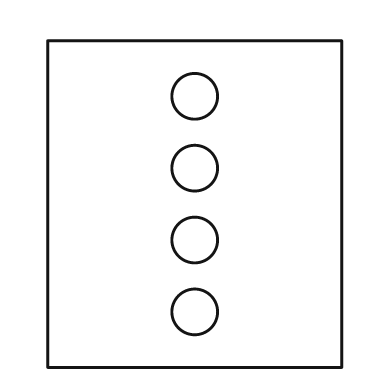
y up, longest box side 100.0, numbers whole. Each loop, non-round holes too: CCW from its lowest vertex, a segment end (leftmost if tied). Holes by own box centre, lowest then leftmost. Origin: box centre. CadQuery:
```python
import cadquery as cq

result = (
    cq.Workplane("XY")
    .moveTo(-45.0, -50.0)
    .lineTo(45.0, -50.0)
    .lineTo(45.0, 50.0)
    .lineTo(-45.0, 50.0)
    .close()
    .moveTo(0.0, -33.0)
    .circle(7.0)
    .moveTo(0.0, -11.0)
    .circle(7.0)
    .moveTo(0.0, 11.0)
    .circle(7.0)
    .moveTo(0.0, 33.0)
    .circle(7.0)
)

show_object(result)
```